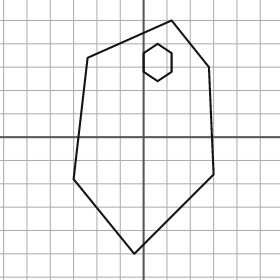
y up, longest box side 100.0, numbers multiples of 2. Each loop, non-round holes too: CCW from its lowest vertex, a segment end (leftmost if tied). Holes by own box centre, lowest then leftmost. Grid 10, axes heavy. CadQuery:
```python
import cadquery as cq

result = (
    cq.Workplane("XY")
    .moveTo(-4.0, -50.0)
    .lineTo(30.0, -16.0)
    .lineTo(28.0, 30.0)
    .lineTo(12.0, 50.0)
    .lineTo(-24.0, 34.0)
    .lineTo(-30.0, -18.0)
    .close()
    .moveTo(6.0, 24.0)
    .lineTo(12.0, 28.0)
    .lineTo(12.0, 36.0)
    .lineTo(6.0, 40.0)
    .lineTo(0.0, 36.0)
    .lineTo(0.0, 28.0)
    .close()
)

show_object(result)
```